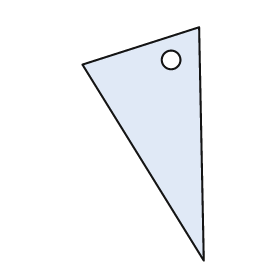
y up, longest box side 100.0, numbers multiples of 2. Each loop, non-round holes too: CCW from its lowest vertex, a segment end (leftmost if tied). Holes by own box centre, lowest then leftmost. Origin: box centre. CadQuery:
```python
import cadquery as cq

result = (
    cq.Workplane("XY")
    .moveTo(26.0, -50.0)
    .lineTo(24.0, 50.0)
    .lineTo(-26.0, 34.0)
    .close()
    .moveTo(12.0, 36.0)
    .circle(4.0)
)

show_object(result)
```